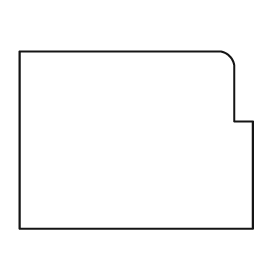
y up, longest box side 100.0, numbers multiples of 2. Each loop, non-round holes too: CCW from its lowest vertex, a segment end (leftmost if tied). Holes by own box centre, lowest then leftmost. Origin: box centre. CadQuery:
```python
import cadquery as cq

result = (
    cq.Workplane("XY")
    .moveTo(-50.0, -38.0)
    .lineTo(50.0, -38.0)
    .lineTo(50.0, 8.0)
    .lineTo(42.0, 8.0)
    .lineTo(42.0, 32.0)
    .threePointArc((40.0, 36.0), (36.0, 38.0))
    .lineTo(-50.0, 38.0)
    .close()
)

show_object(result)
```